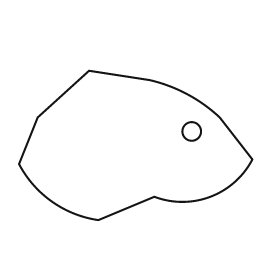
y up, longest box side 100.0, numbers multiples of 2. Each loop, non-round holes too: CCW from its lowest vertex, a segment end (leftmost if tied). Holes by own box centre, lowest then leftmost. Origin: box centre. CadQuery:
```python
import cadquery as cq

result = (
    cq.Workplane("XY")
    .moveTo(-16.0, -32.0)
    .lineTo(8.0, -22.0)
    .threePointArc((32.0, -22.0), (50.0, -6.0))
    .lineTo(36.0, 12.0)
    .threePointArc((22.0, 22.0), (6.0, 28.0))
    .lineTo(-20.0, 32.0)
    .lineTo(-42.0, 12.0)
    .lineTo(-50.0, -8.0)
    .threePointArc((-36.0, -24.0), (-16.0, -32.0))
    .close()
    .moveTo(24.0, 6.0)
    .circle(4.0)
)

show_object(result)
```